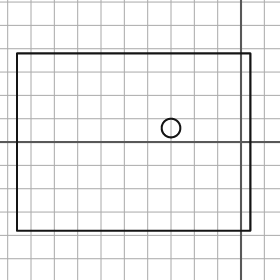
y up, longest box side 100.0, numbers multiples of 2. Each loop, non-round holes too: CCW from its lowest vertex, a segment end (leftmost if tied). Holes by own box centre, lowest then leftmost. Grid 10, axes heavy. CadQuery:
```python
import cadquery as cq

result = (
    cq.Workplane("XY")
    .moveTo(-96.0, -38.0)
    .lineTo(4.0, -38.0)
    .lineTo(4.0, 38.0)
    .lineTo(-96.0, 38.0)
    .close()
    .moveTo(-30.0, 6.0)
    .circle(4.0)
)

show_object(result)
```